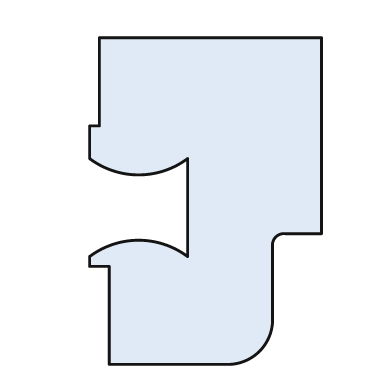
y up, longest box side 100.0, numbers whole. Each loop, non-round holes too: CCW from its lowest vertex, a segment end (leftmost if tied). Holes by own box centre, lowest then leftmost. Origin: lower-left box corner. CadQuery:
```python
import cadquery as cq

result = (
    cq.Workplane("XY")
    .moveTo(6.0, 0.0)
    .lineTo(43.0, 0.0)
    .threePointArc((52.0, 4.0), (56.0, 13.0))
    .lineTo(56.0, 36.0)
    .threePointArc((57.0, 39.0), (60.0, 40.0))
    .lineTo(71.0, 40.0)
    .lineTo(71.0, 100.0)
    .lineTo(3.0, 100.0)
    .lineTo(3.0, 73.0)
    .lineTo(0.0, 73.0)
    .lineTo(0.0, 63.0)
    .threePointArc((15.0, 58.0), (30.0, 63.0))
    .lineTo(30.0, 33.0)
    .threePointArc((15.0, 38.0), (0.0, 33.0))
    .lineTo(0.0, 30.0)
    .lineTo(6.0, 30.0)
    .close()
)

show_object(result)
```